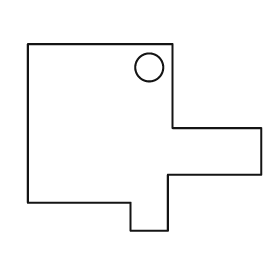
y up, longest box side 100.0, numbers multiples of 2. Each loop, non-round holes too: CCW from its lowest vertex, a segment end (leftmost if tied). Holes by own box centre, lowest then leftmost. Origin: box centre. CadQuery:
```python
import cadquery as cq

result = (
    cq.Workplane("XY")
    .moveTo(-6.0, -40.0)
    .lineTo(10.0, -40.0)
    .lineTo(10.0, -16.0)
    .lineTo(50.0, -16.0)
    .lineTo(50.0, 4.0)
    .lineTo(12.0, 4.0)
    .lineTo(12.0, 40.0)
    .lineTo(-50.0, 40.0)
    .lineTo(-50.0, -28.0)
    .lineTo(-6.0, -28.0)
    .close()
    .moveTo(2.0, 30.0)
    .circle(6.0)
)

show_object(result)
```